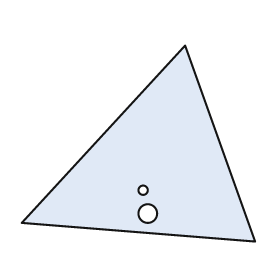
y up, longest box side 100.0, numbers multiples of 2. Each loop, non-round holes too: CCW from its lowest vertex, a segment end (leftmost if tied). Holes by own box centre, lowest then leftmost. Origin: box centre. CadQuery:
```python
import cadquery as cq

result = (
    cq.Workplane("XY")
    .moveTo(50.0, -42.0)
    .lineTo(20.0, 42.0)
    .lineTo(-50.0, -34.0)
    .close()
    .moveTo(4.0, -30.0)
    .circle(4.0)
    .moveTo(2.0, -20.0)
    .circle(2.0)
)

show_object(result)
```